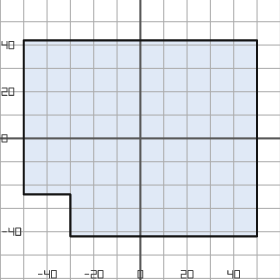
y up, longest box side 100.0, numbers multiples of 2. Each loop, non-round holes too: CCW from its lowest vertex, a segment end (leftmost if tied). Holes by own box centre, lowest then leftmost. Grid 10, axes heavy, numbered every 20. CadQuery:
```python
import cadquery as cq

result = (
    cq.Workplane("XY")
    .moveTo(-30.0, -42.0)
    .lineTo(50.0, -42.0)
    .lineTo(50.0, 42.0)
    .lineTo(-50.0, 42.0)
    .lineTo(-50.0, -24.0)
    .lineTo(-30.0, -24.0)
    .close()
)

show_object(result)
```